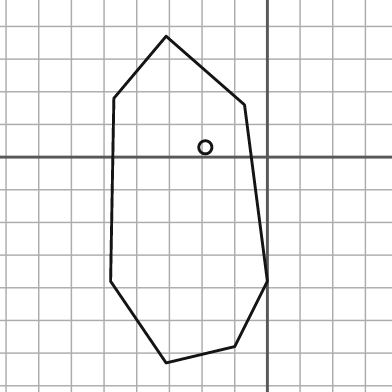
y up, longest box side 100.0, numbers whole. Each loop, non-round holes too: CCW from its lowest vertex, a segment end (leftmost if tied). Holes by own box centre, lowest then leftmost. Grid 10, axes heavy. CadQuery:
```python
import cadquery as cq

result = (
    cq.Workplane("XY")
    .moveTo(-31.0, -63.0)
    .lineTo(-10.0, -58.0)
    .lineTo(0.0, -38.0)
    .lineTo(-7.0, 16.0)
    .lineTo(-31.0, 37.0)
    .lineTo(-47.0, 18.0)
    .lineTo(-48.0, -38.0)
    .close()
    .moveTo(-19.0, 3.0)
    .circle(2.0)
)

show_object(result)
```